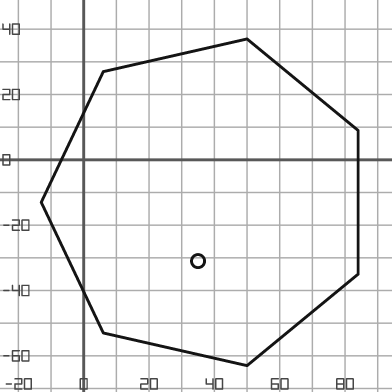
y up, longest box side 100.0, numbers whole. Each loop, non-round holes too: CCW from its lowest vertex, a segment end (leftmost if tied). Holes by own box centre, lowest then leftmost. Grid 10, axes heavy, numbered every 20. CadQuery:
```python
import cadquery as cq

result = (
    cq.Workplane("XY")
    .moveTo(50.0, -63.0)
    .lineTo(84.0, -35.0)
    .lineTo(84.0, 9.0)
    .lineTo(50.0, 37.0)
    .lineTo(6.0, 27.0)
    .lineTo(-13.0, -13.0)
    .lineTo(6.0, -53.0)
    .close()
    .moveTo(35.0, -31.0)
    .circle(2.0)
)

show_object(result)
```